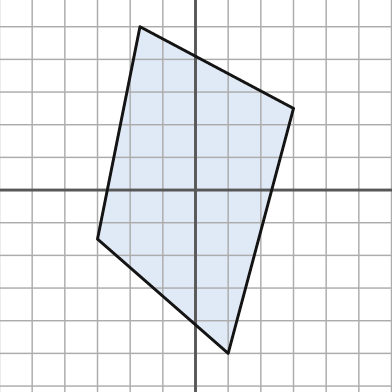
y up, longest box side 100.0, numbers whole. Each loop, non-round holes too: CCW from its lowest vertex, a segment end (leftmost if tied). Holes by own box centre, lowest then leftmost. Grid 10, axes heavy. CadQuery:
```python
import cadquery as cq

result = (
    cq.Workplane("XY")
    .moveTo(10.0, -50.0)
    .lineTo(30.0, 25.0)
    .lineTo(-17.0, 50.0)
    .lineTo(-30.0, -15.0)
    .close()
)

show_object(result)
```